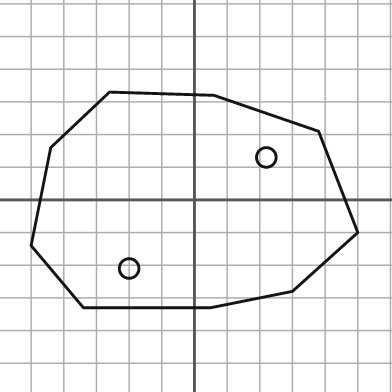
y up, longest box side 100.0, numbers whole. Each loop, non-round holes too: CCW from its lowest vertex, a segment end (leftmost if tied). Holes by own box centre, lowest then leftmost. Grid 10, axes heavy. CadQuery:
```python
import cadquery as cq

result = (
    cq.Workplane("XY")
    .moveTo(-34.0, -33.0)
    .lineTo(5.0, -33.0)
    .lineTo(30.0, -28.0)
    .lineTo(50.0, -10.0)
    .lineTo(38.0, 21.0)
    .lineTo(6.0, 32.0)
    .lineTo(-26.0, 33.0)
    .lineTo(-44.0, 16.0)
    .lineTo(-50.0, -14.0)
    .close()
    .moveTo(-20.0, -21.0)
    .circle(3.0)
    .moveTo(22.0, 13.0)
    .circle(3.0)
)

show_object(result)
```